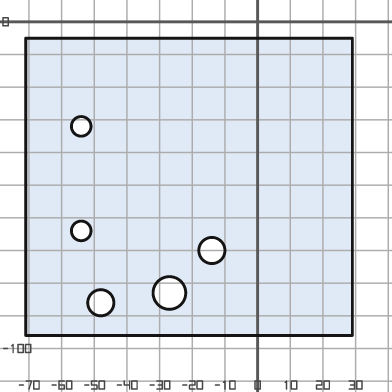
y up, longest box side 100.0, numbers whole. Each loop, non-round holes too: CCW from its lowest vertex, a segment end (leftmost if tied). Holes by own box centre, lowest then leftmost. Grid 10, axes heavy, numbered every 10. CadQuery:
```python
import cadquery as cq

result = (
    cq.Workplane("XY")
    .moveTo(-71.0, -96.0)
    .lineTo(29.0, -96.0)
    .lineTo(29.0, -5.0)
    .lineTo(-71.0, -5.0)
    .close()
    .moveTo(-48.0, -86.0)
    .circle(4.0)
    .moveTo(-27.0, -83.0)
    .circle(5.0)
    .moveTo(-14.0, -70.0)
    .circle(4.0)
    .moveTo(-54.0, -64.0)
    .circle(3.0)
    .moveTo(-54.0, -32.0)
    .circle(3.0)
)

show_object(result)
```